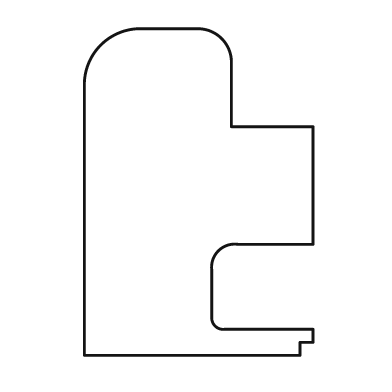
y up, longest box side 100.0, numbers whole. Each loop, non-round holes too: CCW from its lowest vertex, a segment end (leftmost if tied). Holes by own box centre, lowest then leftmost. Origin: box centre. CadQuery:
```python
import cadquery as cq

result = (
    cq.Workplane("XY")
    .moveTo(-35.0, -50.0)
    .lineTo(31.0, -50.0)
    .lineTo(31.0, -46.0)
    .lineTo(35.0, -46.0)
    .lineTo(35.0, -42.0)
    .lineTo(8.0, -42.0)
    .threePointArc((5.0, -41.0), (4.0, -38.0))
    .lineTo(4.0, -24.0)
    .threePointArc((6.0, -18.0), (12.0, -16.0))
    .lineTo(35.0, -16.0)
    .lineTo(35.0, 20.0)
    .lineTo(10.0, 20.0)
    .lineTo(10.0, 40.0)
    .threePointArc((7.0, 47.0), (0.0, 50.0))
    .lineTo(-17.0, 50.0)
    .threePointArc((-30.0, 45.0), (-35.0, 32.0))
    .close()
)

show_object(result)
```